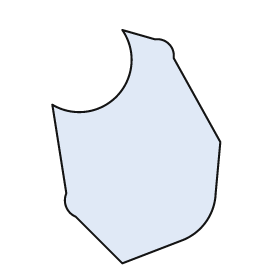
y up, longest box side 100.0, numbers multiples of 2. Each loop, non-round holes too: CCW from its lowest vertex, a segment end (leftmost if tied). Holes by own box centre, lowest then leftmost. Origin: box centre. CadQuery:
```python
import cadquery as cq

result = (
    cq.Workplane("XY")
    .moveTo(-6.0, -50.0)
    .lineTo(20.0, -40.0)
    .threePointArc((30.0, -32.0), (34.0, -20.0))
    .lineTo(36.0, 2.0)
    .lineTo(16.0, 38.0)
    .threePointArc((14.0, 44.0), (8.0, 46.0))
    .lineTo(-6.0, 50.0)
    .threePointArc((-8.0, 22.0), (-36.0, 18.0))
    .lineTo(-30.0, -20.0)
    .threePointArc((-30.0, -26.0), (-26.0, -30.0))
    .close()
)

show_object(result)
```